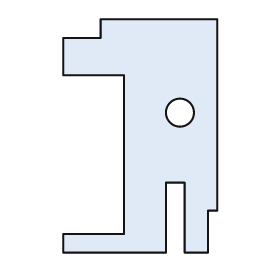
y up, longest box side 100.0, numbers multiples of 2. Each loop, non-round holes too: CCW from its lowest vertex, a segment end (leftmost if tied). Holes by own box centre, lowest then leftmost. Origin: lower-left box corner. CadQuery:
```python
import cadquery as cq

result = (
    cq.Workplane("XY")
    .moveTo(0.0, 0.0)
    .lineTo(44.0, 0.0)
    .lineTo(44.0, 30.0)
    .lineTo(52.0, 30.0)
    .lineTo(52.0, 0.0)
    .lineTo(62.0, 0.0)
    .lineTo(62.0, 18.0)
    .lineTo(66.0, 18.0)
    .lineTo(66.0, 100.0)
    .lineTo(16.0, 100.0)
    .lineTo(16.0, 92.0)
    .lineTo(0.0, 92.0)
    .lineTo(0.0, 76.0)
    .lineTo(26.0, 76.0)
    .lineTo(26.0, 8.0)
    .lineTo(0.0, 8.0)
    .close()
    .moveTo(50.0, 60.0)
    .circle(6.0)
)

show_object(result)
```